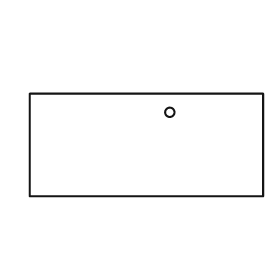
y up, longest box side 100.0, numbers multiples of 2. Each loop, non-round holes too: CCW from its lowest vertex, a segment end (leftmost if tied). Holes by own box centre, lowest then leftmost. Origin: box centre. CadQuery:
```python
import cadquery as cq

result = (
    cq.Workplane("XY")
    .moveTo(-50.0, -22.0)
    .lineTo(50.0, -22.0)
    .lineTo(50.0, 22.0)
    .lineTo(-50.0, 22.0)
    .close()
    .moveTo(10.0, 14.0)
    .circle(2.0)
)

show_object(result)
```